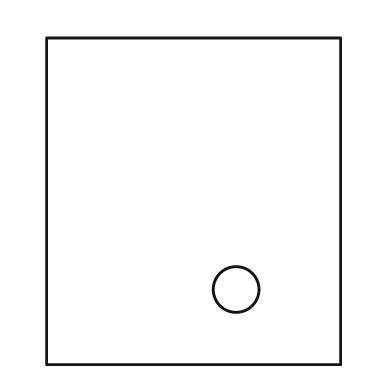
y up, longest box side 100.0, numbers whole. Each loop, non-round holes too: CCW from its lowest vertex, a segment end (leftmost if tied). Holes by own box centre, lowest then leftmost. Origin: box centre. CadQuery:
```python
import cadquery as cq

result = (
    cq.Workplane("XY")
    .moveTo(-45.0, -50.0)
    .lineTo(45.0, -50.0)
    .lineTo(45.0, 50.0)
    .lineTo(-45.0, 50.0)
    .close()
    .moveTo(13.0, -27.0)
    .circle(7.0)
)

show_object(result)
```